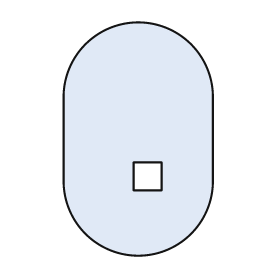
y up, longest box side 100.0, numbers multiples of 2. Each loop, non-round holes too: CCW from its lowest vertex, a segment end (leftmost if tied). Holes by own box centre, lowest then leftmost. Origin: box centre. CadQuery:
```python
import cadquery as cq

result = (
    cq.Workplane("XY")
    .moveTo(-32.0, -18.0)
    .threePointArc((0.0, -50.0), (32.0, -18.0))
    .lineTo(32.0, 18.0)
    .threePointArc((0.0, 50.0), (-32.0, 18.0))
    .close()
    .moveTo(-2.0, -22.0)
    .lineTo(10.0, -22.0)
    .lineTo(10.0, -10.0)
    .lineTo(-2.0, -10.0)
    .close()
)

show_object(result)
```